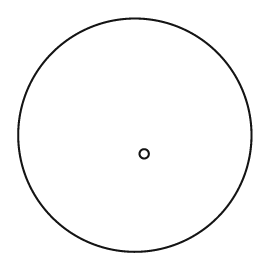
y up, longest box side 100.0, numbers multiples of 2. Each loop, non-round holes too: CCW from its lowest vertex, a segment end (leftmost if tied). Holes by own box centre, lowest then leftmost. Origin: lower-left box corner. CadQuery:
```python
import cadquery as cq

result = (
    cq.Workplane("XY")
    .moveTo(50.0, 50.0)
    .circle(50.0)
    .moveTo(54.0, 42.0)
    .circle(2.0)
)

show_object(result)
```